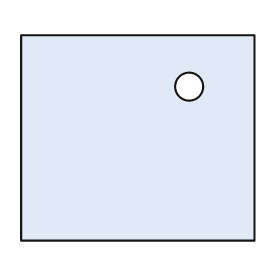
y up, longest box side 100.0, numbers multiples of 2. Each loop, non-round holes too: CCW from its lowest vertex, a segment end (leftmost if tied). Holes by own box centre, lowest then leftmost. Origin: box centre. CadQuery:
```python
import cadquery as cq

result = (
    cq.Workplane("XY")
    .moveTo(-50.0, -44.0)
    .lineTo(50.0, -44.0)
    .lineTo(50.0, 44.0)
    .lineTo(-50.0, 44.0)
    .close()
    .moveTo(22.0, 22.0)
    .circle(6.0)
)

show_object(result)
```